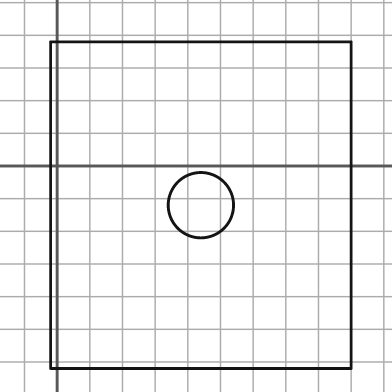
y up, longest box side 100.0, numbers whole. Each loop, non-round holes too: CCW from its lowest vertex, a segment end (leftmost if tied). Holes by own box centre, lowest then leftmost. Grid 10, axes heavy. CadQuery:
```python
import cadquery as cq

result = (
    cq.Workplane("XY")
    .moveTo(-2.0, -62.0)
    .lineTo(90.0, -62.0)
    .lineTo(90.0, 38.0)
    .lineTo(-2.0, 38.0)
    .close()
    .moveTo(44.0, -12.0)
    .circle(10.0)
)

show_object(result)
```